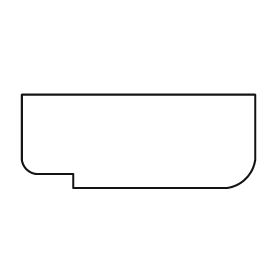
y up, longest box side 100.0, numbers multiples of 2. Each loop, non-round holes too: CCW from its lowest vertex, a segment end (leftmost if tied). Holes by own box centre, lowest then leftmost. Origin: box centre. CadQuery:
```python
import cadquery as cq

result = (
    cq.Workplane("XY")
    .moveTo(-28.0, -20.0)
    .lineTo(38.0, -20.0)
    .threePointArc((46.0, -16.0), (50.0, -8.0))
    .lineTo(50.0, 20.0)
    .lineTo(-50.0, 20.0)
    .lineTo(-50.0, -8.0)
    .threePointArc((-48.0, -12.0), (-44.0, -14.0))
    .lineTo(-28.0, -14.0)
    .close()
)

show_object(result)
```